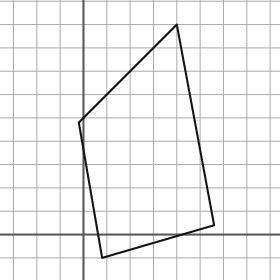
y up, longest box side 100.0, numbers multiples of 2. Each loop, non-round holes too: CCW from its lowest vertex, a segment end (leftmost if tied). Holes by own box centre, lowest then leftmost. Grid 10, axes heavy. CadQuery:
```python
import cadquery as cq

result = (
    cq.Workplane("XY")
    .moveTo(8.0, -10.0)
    .lineTo(56.0, 4.0)
    .lineTo(40.0, 90.0)
    .lineTo(-2.0, 48.0)
    .close()
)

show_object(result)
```